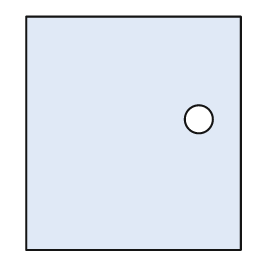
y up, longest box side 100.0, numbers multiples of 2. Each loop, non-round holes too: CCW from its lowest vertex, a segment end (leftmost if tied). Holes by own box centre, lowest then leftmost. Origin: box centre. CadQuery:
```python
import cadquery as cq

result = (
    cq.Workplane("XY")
    .moveTo(-46.0, -50.0)
    .lineTo(46.0, -50.0)
    .lineTo(46.0, 50.0)
    .lineTo(-46.0, 50.0)
    .close()
    .moveTo(28.0, 6.0)
    .circle(6.0)
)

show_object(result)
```